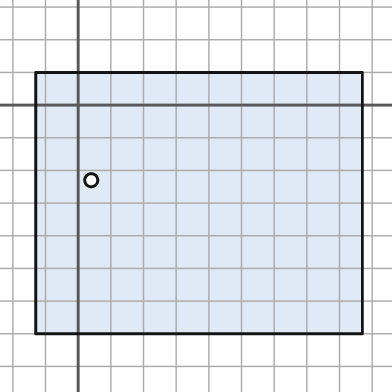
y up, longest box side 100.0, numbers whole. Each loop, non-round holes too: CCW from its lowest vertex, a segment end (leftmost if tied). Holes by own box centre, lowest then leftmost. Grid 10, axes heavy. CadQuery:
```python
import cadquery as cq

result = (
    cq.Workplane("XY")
    .moveTo(-13.0, -70.0)
    .lineTo(87.0, -70.0)
    .lineTo(87.0, 10.0)
    .lineTo(-13.0, 10.0)
    .close()
    .moveTo(4.0, -23.0)
    .circle(2.0)
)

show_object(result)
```